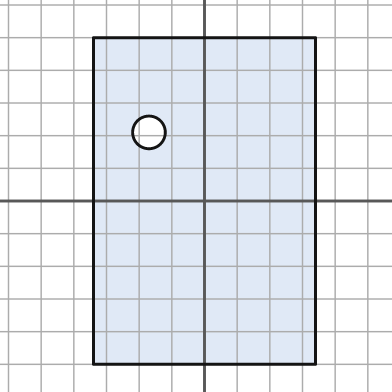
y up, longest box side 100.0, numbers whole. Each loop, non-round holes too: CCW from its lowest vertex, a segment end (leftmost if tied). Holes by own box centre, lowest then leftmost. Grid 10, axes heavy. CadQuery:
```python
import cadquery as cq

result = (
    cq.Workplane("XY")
    .moveTo(-34.0, -50.0)
    .lineTo(34.0, -50.0)
    .lineTo(34.0, 50.0)
    .lineTo(-34.0, 50.0)
    .close()
    .moveTo(-17.0, 21.0)
    .circle(5.0)
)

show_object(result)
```